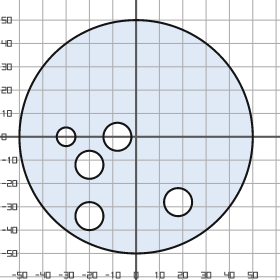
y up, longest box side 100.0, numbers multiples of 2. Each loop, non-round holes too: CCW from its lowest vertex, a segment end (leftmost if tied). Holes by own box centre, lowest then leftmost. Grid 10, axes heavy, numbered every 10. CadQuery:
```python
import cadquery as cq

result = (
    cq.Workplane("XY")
    .moveTo(0.0, 0.0)
    .circle(50.0)
    .moveTo(-20.0, -34.0)
    .circle(6.0)
    .moveTo(18.0, -28.0)
    .circle(6.0)
    .moveTo(-20.0, -12.0)
    .circle(6.0)
    .moveTo(-30.0, 0.0)
    .circle(4.0)
    .moveTo(-8.0, 0.0)
    .circle(6.0)
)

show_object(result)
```